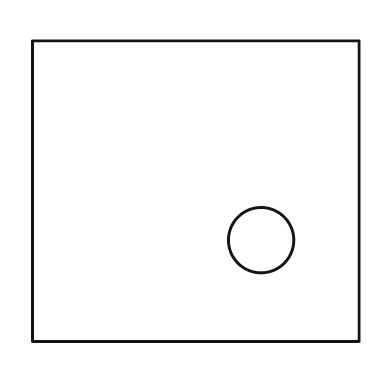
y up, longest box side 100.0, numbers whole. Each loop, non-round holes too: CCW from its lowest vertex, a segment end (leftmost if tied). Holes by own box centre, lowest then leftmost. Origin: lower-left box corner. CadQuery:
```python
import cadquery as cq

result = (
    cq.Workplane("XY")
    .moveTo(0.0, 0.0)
    .lineTo(100.0, 0.0)
    .lineTo(100.0, 92.0)
    .lineTo(0.0, 92.0)
    .close()
    .moveTo(70.0, 31.0)
    .circle(10.0)
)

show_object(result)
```